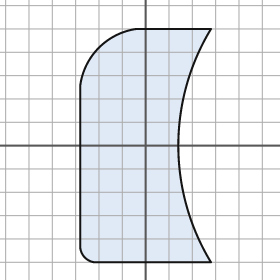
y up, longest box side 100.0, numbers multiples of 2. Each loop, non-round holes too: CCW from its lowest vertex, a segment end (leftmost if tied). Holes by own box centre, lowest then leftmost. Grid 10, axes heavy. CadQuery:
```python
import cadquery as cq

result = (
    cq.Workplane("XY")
    .moveTo(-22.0, -50.0)
    .lineTo(28.0, -50.0)
    .threePointArc((14.0, 0.0), (28.0, 50.0))
    .lineTo(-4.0, 50.0)
    .threePointArc((-20.0, 42.0), (-28.0, 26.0))
    .lineTo(-28.0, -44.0)
    .threePointArc((-26.0, -48.0), (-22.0, -50.0))
    .close()
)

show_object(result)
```